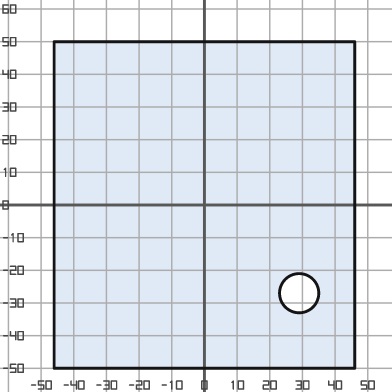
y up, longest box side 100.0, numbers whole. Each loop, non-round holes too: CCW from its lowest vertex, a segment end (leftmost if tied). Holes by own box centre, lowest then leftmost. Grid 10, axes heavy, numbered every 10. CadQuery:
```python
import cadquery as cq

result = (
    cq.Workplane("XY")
    .moveTo(-46.0, -50.0)
    .lineTo(46.0, -50.0)
    .lineTo(46.0, 50.0)
    .lineTo(-46.0, 50.0)
    .close()
    .moveTo(29.0, -27.0)
    .circle(6.0)
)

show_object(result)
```